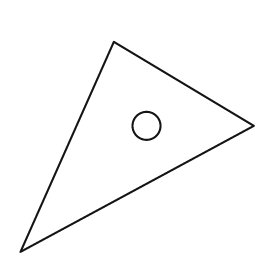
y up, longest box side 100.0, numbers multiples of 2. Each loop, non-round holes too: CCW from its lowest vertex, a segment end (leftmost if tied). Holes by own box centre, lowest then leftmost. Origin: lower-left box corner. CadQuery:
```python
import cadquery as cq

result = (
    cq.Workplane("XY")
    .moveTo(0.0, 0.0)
    .lineTo(100.0, 54.0)
    .lineTo(40.0, 90.0)
    .close()
    .moveTo(54.0, 54.0)
    .circle(6.0)
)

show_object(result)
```